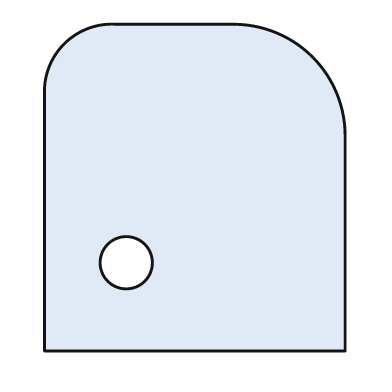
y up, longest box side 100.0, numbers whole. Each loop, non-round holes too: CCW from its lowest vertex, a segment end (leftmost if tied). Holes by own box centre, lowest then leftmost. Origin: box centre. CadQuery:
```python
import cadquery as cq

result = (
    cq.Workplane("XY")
    .moveTo(-46.0, -50.0)
    .lineTo(46.0, -50.0)
    .lineTo(46.0, 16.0)
    .threePointArc((36.0, 40.0), (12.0, 50.0))
    .lineTo(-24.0, 50.0)
    .threePointArc((-40.0, 44.0), (-46.0, 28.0))
    .close()
    .moveTo(-21.0, -23.0)
    .circle(8.0)
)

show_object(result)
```